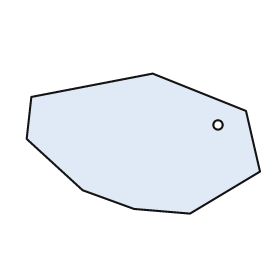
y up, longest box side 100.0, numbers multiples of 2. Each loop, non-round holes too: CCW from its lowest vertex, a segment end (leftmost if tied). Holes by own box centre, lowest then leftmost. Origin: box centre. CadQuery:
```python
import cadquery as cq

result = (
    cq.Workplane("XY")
    .moveTo(20.0, -30.0)
    .lineTo(50.0, -12.0)
    .lineTo(44.0, 14.0)
    .lineTo(4.0, 30.0)
    .lineTo(-48.0, 20.0)
    .lineTo(-50.0, 2.0)
    .lineTo(-26.0, -20.0)
    .lineTo(-4.0, -28.0)
    .close()
    .moveTo(32.0, 8.0)
    .circle(2.0)
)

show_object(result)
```